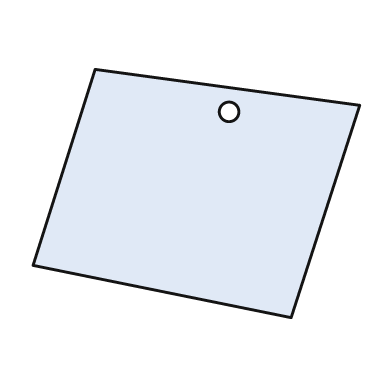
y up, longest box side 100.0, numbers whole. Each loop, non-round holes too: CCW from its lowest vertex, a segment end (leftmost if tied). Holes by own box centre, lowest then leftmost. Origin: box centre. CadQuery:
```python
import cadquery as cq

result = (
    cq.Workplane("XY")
    .moveTo(29.0, -38.0)
    .lineTo(50.0, 27.0)
    .lineTo(-31.0, 38.0)
    .lineTo(-50.0, -22.0)
    .close()
    .moveTo(10.0, 25.0)
    .circle(3.0)
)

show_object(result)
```